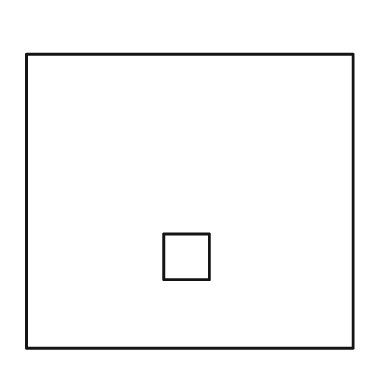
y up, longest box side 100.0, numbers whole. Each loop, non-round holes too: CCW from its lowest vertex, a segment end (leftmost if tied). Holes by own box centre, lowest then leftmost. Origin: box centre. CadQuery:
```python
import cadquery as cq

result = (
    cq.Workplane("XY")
    .moveTo(-50.0, -45.0)
    .lineTo(50.0, -45.0)
    .lineTo(50.0, 45.0)
    .lineTo(-50.0, 45.0)
    .close()
    .moveTo(-8.0, -24.0)
    .lineTo(6.0, -24.0)
    .lineTo(6.0, -10.0)
    .lineTo(-8.0, -10.0)
    .close()
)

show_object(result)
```